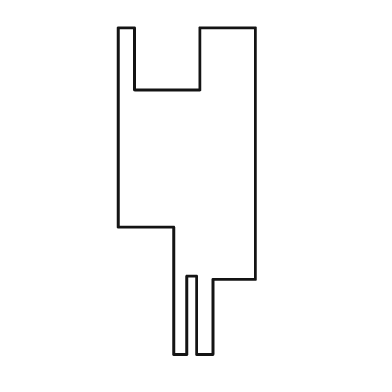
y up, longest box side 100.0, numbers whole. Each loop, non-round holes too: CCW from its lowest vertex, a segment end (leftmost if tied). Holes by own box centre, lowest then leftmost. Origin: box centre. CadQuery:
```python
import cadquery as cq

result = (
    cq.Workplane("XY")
    .moveTo(-4.0, -50.0)
    .lineTo(0.0, -50.0)
    .lineTo(0.0, -26.0)
    .lineTo(3.0, -26.0)
    .lineTo(3.0, -50.0)
    .lineTo(8.0, -50.0)
    .lineTo(8.0, -27.0)
    .lineTo(21.0, -27.0)
    .lineTo(21.0, 50.0)
    .lineTo(4.0, 50.0)
    .lineTo(4.0, 31.0)
    .lineTo(-16.0, 31.0)
    .lineTo(-16.0, 50.0)
    .lineTo(-21.0, 50.0)
    .lineTo(-21.0, -11.0)
    .lineTo(-4.0, -11.0)
    .close()
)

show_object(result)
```